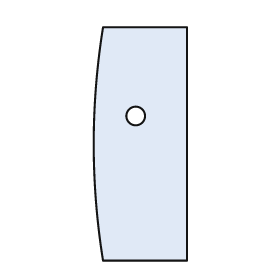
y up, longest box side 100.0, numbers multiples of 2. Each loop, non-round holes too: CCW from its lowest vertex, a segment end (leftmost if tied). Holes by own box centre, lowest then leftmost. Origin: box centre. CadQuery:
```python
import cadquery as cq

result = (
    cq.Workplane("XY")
    .moveTo(-16.0, -50.0)
    .lineTo(20.0, -50.0)
    .lineTo(20.0, 50.0)
    .lineTo(-16.0, 50.0)
    .threePointArc((-20.0, 0.0), (-16.0, -50.0))
    .close()
    .moveTo(-2.0, 12.0)
    .circle(4.0)
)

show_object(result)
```